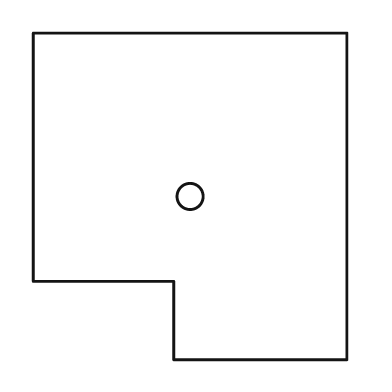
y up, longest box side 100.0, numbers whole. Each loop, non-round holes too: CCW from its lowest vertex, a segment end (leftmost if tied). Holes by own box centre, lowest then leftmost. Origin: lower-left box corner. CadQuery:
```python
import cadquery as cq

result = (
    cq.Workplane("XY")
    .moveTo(43.0, 0.0)
    .lineTo(96.0, 0.0)
    .lineTo(96.0, 100.0)
    .lineTo(0.0, 100.0)
    .lineTo(0.0, 24.0)
    .lineTo(43.0, 24.0)
    .close()
    .moveTo(48.0, 50.0)
    .circle(4.0)
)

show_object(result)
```